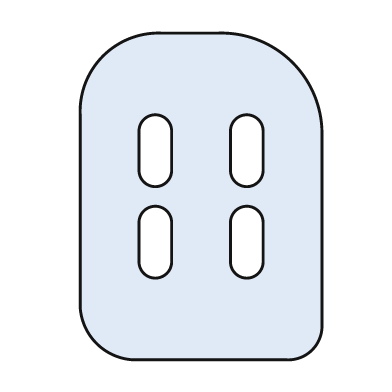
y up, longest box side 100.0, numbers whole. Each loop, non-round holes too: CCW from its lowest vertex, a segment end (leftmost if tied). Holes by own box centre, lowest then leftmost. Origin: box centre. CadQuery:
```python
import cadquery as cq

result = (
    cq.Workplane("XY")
    .moveTo(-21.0, -50.0)
    .lineTo(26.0, -50.0)
    .threePointArc((34.0, -47.0), (37.0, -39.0))
    .lineTo(37.0, 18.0)
    .threePointArc((28.0, 41.0), (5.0, 50.0))
    .lineTo(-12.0, 50.0)
    .threePointArc((-30.0, 43.0), (-37.0, 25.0))
    .lineTo(-37.0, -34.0)
    .threePointArc((-32.0, -45.0), (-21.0, -50.0))
    .close()
    .moveTo(-19.0, -20.0)
    .threePointArc((-14.0, -25.0), (-9.0, -20.0))
    .lineTo(-9.0, -8.0)
    .threePointArc((-14.0, -3.0), (-19.0, -8.0))
    .close()
    .moveTo(9.0, -20.0)
    .threePointArc((14.0, -25.0), (19.0, -20.0))
    .lineTo(19.0, -8.0)
    .threePointArc((14.0, -3.0), (9.0, -8.0))
    .close()
    .moveTo(-19.0, 8.0)
    .threePointArc((-14.0, 3.0), (-9.0, 8.0))
    .lineTo(-9.0, 20.0)
    .threePointArc((-14.0, 25.0), (-19.0, 20.0))
    .close()
    .moveTo(9.0, 8.0)
    .threePointArc((14.0, 3.0), (19.0, 8.0))
    .lineTo(19.0, 20.0)
    .threePointArc((14.0, 25.0), (9.0, 20.0))
    .close()
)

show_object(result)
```